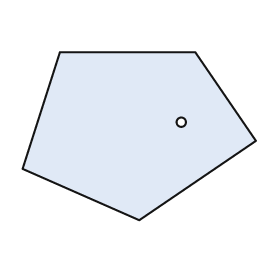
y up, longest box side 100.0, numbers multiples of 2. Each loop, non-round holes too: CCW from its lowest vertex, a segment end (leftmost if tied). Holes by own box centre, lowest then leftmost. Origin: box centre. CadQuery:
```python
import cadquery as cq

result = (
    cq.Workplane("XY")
    .moveTo(0.0, -36.0)
    .lineTo(50.0, -2.0)
    .lineTo(24.0, 36.0)
    .lineTo(-34.0, 36.0)
    .lineTo(-50.0, -14.0)
    .close()
    .moveTo(18.0, 6.0)
    .circle(2.0)
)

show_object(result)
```